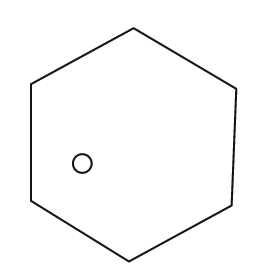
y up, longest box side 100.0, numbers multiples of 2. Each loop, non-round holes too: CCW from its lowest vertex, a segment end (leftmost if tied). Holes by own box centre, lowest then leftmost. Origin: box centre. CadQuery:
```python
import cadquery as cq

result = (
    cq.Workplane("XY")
    .moveTo(-2.0, -50.0)
    .lineTo(42.0, -26.0)
    .lineTo(44.0, 24.0)
    .lineTo(0.0, 50.0)
    .lineTo(-44.0, 26.0)
    .lineTo(-44.0, -24.0)
    .close()
    .moveTo(-22.0, -8.0)
    .circle(4.0)
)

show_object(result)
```